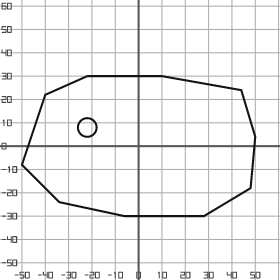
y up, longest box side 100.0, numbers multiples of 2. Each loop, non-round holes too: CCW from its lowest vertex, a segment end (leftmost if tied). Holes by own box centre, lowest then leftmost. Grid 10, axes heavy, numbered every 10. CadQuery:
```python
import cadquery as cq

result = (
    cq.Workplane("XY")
    .moveTo(-6.0, -30.0)
    .lineTo(28.0, -30.0)
    .lineTo(48.0, -18.0)
    .lineTo(50.0, 4.0)
    .lineTo(44.0, 24.0)
    .lineTo(10.0, 30.0)
    .lineTo(-22.0, 30.0)
    .lineTo(-40.0, 22.0)
    .lineTo(-50.0, -8.0)
    .lineTo(-34.0, -24.0)
    .close()
    .moveTo(-22.0, 8.0)
    .circle(4.0)
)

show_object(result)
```